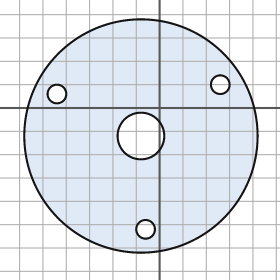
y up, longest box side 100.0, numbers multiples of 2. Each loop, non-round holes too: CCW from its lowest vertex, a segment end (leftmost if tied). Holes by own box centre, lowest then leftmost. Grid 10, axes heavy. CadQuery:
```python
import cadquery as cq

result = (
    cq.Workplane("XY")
    .moveTo(-8.0, -12.0)
    .circle(50.0)
    .moveTo(-6.0, -52.0)
    .circle(4.0)
    .moveTo(-8.0, -12.0)
    .circle(10.0)
    .moveTo(-44.0, 6.0)
    .circle(4.0)
    .moveTo(26.0, 10.0)
    .circle(4.0)
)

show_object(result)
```